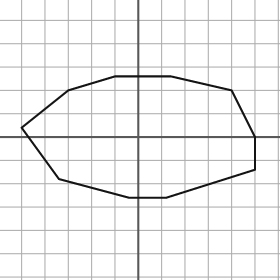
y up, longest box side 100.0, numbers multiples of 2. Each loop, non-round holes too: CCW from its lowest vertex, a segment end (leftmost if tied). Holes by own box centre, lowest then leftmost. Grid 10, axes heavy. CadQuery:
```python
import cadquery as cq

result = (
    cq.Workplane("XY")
    .moveTo(-4.0, -26.0)
    .lineTo(12.0, -26.0)
    .lineTo(50.0, -14.0)
    .lineTo(50.0, 0.0)
    .lineTo(40.0, 20.0)
    .lineTo(14.0, 26.0)
    .lineTo(-10.0, 26.0)
    .lineTo(-30.0, 20.0)
    .lineTo(-50.0, 4.0)
    .lineTo(-34.0, -18.0)
    .close()
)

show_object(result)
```